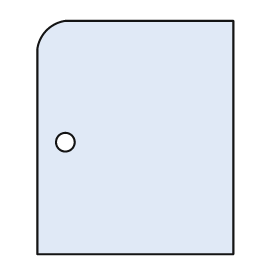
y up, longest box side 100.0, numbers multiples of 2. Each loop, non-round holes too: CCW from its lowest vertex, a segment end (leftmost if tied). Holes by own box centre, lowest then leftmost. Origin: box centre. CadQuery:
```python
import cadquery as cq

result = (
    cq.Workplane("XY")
    .moveTo(-42.0, -50.0)
    .lineTo(42.0, -50.0)
    .lineTo(42.0, 50.0)
    .lineTo(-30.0, 50.0)
    .threePointArc((-38.0, 46.0), (-42.0, 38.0))
    .close()
    .moveTo(-30.0, -2.0)
    .circle(4.0)
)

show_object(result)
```